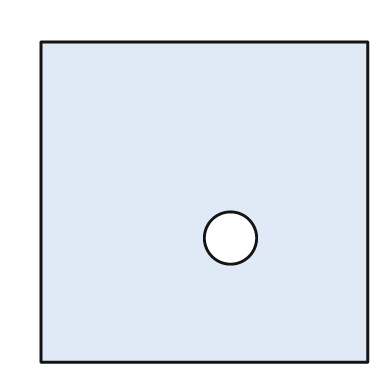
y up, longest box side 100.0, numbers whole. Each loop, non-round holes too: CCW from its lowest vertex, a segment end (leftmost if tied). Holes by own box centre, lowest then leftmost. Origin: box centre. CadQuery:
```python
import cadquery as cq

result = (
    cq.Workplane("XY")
    .moveTo(-50.0, -49.0)
    .lineTo(50.0, -49.0)
    .lineTo(50.0, 49.0)
    .lineTo(-50.0, 49.0)
    .close()
    .moveTo(8.0, -11.0)
    .circle(8.0)
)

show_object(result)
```